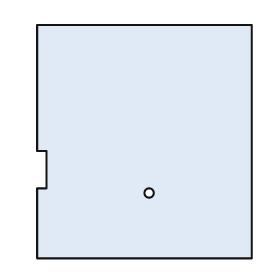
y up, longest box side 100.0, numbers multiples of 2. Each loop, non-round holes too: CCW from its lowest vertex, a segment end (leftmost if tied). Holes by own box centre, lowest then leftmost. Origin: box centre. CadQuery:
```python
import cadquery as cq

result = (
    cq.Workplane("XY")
    .moveTo(-46.0, -50.0)
    .lineTo(46.0, -50.0)
    .lineTo(46.0, 50.0)
    .lineTo(-46.0, 50.0)
    .lineTo(-46.0, -4.0)
    .lineTo(-42.0, -4.0)
    .lineTo(-42.0, -20.0)
    .lineTo(-46.0, -20.0)
    .close()
    .moveTo(2.0, -22.0)
    .circle(2.0)
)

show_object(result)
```